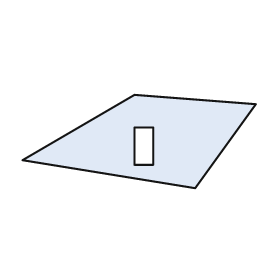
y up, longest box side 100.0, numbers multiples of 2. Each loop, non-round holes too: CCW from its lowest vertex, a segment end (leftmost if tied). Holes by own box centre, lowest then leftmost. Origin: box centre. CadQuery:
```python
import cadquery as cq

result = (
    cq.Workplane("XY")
    .moveTo(24.0, -20.0)
    .lineTo(50.0, 16.0)
    .lineTo(-2.0, 20.0)
    .lineTo(-50.0, -8.0)
    .close()
    .moveTo(-2.0, -10.0)
    .lineTo(6.0, -10.0)
    .lineTo(6.0, 6.0)
    .lineTo(-2.0, 6.0)
    .close()
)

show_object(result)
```